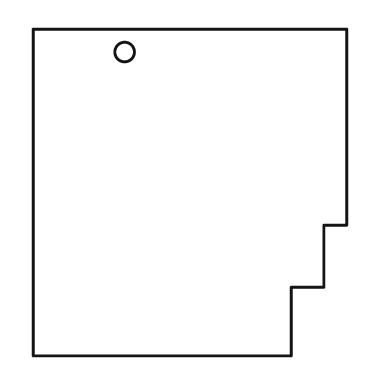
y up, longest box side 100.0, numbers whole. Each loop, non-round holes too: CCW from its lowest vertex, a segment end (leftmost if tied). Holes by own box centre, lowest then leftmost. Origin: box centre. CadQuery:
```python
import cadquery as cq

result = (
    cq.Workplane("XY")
    .moveTo(-48.0, -50.0)
    .lineTo(31.0, -50.0)
    .lineTo(31.0, -29.0)
    .lineTo(41.0, -29.0)
    .lineTo(41.0, -10.0)
    .lineTo(48.0, -10.0)
    .lineTo(48.0, 50.0)
    .lineTo(-48.0, 50.0)
    .close()
    .moveTo(-20.0, 43.0)
    .circle(3.0)
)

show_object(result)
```